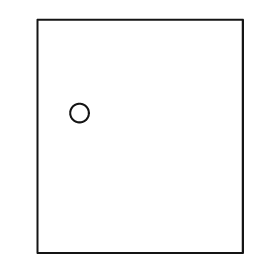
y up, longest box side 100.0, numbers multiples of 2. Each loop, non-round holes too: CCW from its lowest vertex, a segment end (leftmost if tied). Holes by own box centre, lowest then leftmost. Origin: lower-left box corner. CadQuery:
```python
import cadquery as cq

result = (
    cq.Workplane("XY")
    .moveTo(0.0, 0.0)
    .lineTo(88.0, 0.0)
    .lineTo(88.0, 100.0)
    .lineTo(0.0, 100.0)
    .close()
    .moveTo(18.0, 60.0)
    .circle(4.0)
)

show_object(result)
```